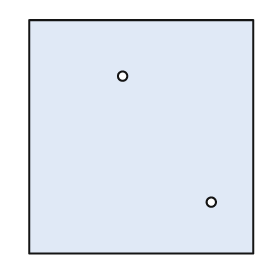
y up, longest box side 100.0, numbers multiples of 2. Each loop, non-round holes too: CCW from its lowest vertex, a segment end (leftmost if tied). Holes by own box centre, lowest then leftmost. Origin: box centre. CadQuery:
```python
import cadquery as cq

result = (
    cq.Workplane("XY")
    .moveTo(-48.0, -50.0)
    .lineTo(48.0, -50.0)
    .lineTo(48.0, 50.0)
    .lineTo(-48.0, 50.0)
    .close()
    .moveTo(30.0, -28.0)
    .circle(2.0)
    .moveTo(-8.0, 26.0)
    .circle(2.0)
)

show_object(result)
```